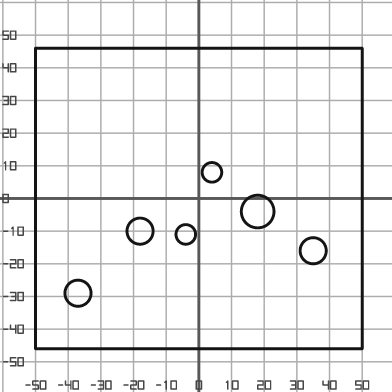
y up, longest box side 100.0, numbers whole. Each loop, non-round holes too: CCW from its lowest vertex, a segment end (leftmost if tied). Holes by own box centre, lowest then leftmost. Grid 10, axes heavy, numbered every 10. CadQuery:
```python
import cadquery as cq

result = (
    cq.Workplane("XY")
    .moveTo(-50.0, -46.0)
    .lineTo(50.0, -46.0)
    .lineTo(50.0, 46.0)
    .lineTo(-50.0, 46.0)
    .close()
    .moveTo(-37.0, -29.0)
    .circle(4.0)
    .moveTo(35.0, -16.0)
    .circle(4.0)
    .moveTo(-4.0, -11.0)
    .circle(3.0)
    .moveTo(-18.0, -10.0)
    .circle(4.0)
    .moveTo(18.0, -4.0)
    .circle(5.0)
    .moveTo(4.0, 8.0)
    .circle(3.0)
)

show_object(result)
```